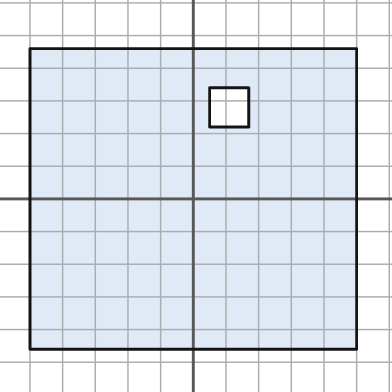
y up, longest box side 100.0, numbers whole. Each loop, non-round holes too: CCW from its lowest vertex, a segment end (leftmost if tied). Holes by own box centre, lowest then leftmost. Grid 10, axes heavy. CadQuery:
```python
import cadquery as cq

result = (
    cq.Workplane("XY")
    .moveTo(-50.0, -46.0)
    .lineTo(50.0, -46.0)
    .lineTo(50.0, 46.0)
    .lineTo(-50.0, 46.0)
    .close()
    .moveTo(5.0, 22.0)
    .lineTo(17.0, 22.0)
    .lineTo(17.0, 34.0)
    .lineTo(5.0, 34.0)
    .close()
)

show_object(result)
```